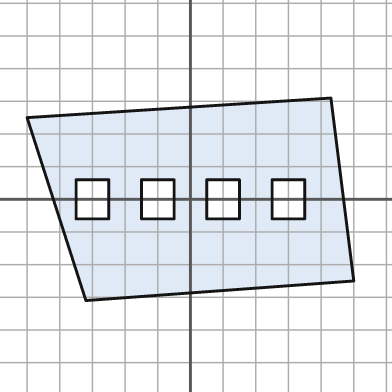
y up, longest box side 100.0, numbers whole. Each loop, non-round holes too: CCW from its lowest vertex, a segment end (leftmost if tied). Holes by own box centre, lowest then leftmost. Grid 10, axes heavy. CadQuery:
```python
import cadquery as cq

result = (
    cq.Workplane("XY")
    .moveTo(-32.0, -31.0)
    .lineTo(50.0, -25.0)
    .lineTo(43.0, 31.0)
    .lineTo(-50.0, 25.0)
    .close()
    .moveTo(-35.0, -6.0)
    .lineTo(-25.0, -6.0)
    .lineTo(-25.0, 6.0)
    .lineTo(-35.0, 6.0)
    .close()
    .moveTo(-15.0, -6.0)
    .lineTo(-5.0, -6.0)
    .lineTo(-5.0, 6.0)
    .lineTo(-15.0, 6.0)
    .close()
    .moveTo(5.0, -6.0)
    .lineTo(15.0, -6.0)
    .lineTo(15.0, 6.0)
    .lineTo(5.0, 6.0)
    .close()
    .moveTo(25.0, -6.0)
    .lineTo(35.0, -6.0)
    .lineTo(35.0, 6.0)
    .lineTo(25.0, 6.0)
    .close()
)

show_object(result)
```